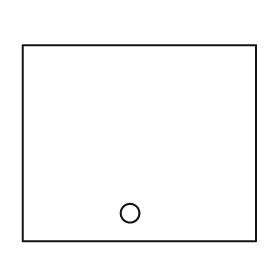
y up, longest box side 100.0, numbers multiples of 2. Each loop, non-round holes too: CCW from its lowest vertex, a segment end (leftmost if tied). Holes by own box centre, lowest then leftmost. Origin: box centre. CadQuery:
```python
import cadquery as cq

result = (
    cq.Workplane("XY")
    .moveTo(-50.0, -42.0)
    .lineTo(50.0, -42.0)
    .lineTo(50.0, 42.0)
    .lineTo(-50.0, 42.0)
    .close()
    .moveTo(-4.0, -30.0)
    .circle(4.0)
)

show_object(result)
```